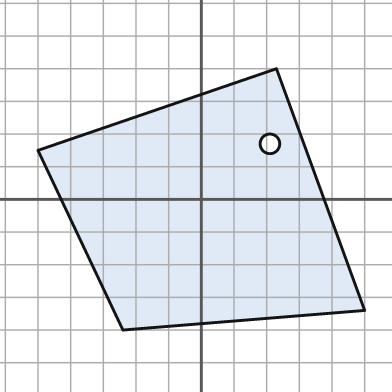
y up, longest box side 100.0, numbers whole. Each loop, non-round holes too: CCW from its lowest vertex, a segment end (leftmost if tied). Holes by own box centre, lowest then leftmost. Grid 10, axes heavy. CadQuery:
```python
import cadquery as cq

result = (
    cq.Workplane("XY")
    .moveTo(-24.0, -40.0)
    .lineTo(50.0, -34.0)
    .lineTo(23.0, 40.0)
    .lineTo(-50.0, 15.0)
    .close()
    .moveTo(21.0, 17.0)
    .circle(3.0)
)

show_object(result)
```